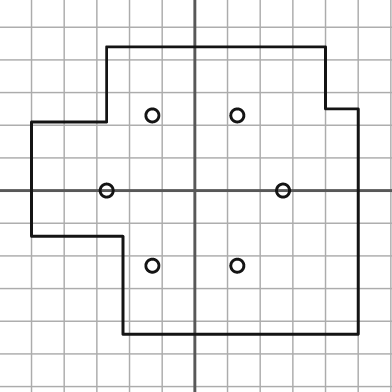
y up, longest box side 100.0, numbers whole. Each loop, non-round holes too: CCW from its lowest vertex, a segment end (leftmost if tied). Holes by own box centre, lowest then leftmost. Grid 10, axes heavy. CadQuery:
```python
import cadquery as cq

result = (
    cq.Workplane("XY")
    .moveTo(-22.0, -44.0)
    .lineTo(50.0, -44.0)
    .lineTo(50.0, 25.0)
    .lineTo(40.0, 25.0)
    .lineTo(40.0, 44.0)
    .lineTo(-27.0, 44.0)
    .lineTo(-27.0, 21.0)
    .lineTo(-50.0, 21.0)
    .lineTo(-50.0, -14.0)
    .lineTo(-22.0, -14.0)
    .close()
    .moveTo(-13.0, -23.0)
    .circle(2.0)
    .moveTo(13.0, -23.0)
    .circle(2.0)
    .moveTo(-27.0, 0.0)
    .circle(2.0)
    .moveTo(27.0, 0.0)
    .circle(2.0)
    .moveTo(-13.0, 23.0)
    .circle(2.0)
    .moveTo(13.0, 23.0)
    .circle(2.0)
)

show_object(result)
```